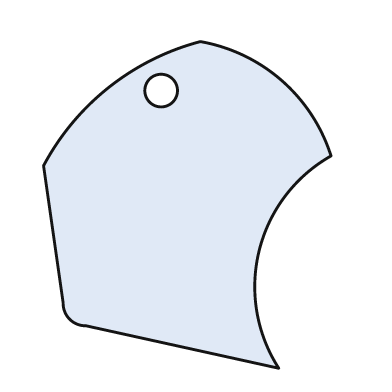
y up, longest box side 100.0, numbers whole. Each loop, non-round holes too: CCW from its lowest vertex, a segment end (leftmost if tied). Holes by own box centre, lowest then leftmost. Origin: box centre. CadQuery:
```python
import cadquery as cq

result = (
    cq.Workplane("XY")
    .moveTo(28.0, -50.0)
    .threePointArc((22.0, -14.0), (44.0, 15.0))
    .threePointArc((29.0, 38.0), (4.0, 50.0))
    .threePointArc((-24.0, 36.0), (-44.0, 12.0))
    .lineTo(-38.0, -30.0)
    .threePointArc((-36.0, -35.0), (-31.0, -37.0))
    .close()
    .moveTo(-8.0, 35.0)
    .circle(5.0)
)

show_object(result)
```